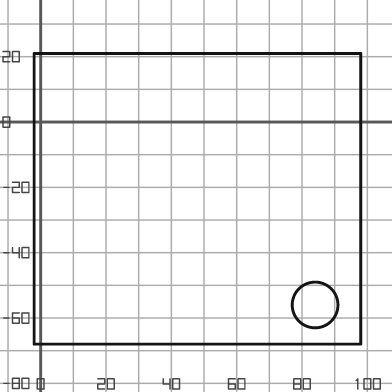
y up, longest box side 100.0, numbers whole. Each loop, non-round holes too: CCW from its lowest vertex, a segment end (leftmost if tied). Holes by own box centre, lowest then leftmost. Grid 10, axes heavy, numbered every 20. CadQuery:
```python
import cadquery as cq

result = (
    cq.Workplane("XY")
    .moveTo(-2.0, -68.0)
    .lineTo(98.0, -68.0)
    .lineTo(98.0, 21.0)
    .lineTo(-2.0, 21.0)
    .close()
    .moveTo(84.0, -56.0)
    .circle(7.0)
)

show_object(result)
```